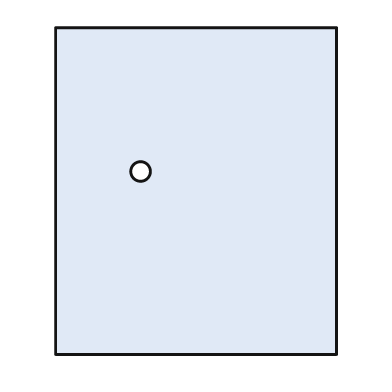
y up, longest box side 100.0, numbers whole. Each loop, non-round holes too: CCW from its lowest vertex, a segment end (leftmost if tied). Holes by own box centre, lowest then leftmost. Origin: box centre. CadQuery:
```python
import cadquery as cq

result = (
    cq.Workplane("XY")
    .moveTo(-43.0, -50.0)
    .lineTo(43.0, -50.0)
    .lineTo(43.0, 50.0)
    .lineTo(-43.0, 50.0)
    .close()
    .moveTo(-17.0, 6.0)
    .circle(3.0)
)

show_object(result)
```